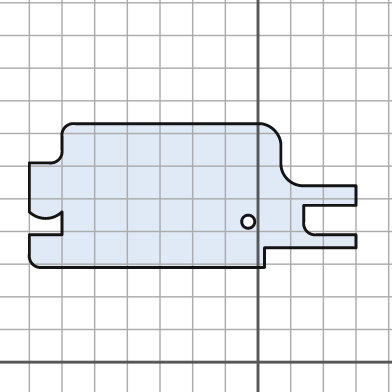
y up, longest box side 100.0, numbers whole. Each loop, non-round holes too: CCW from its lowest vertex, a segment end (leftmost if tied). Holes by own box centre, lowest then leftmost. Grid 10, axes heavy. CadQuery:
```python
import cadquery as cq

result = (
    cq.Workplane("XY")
    .moveTo(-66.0, 29.0)
    .lineTo(2.0, 29.0)
    .lineTo(2.0, 35.0)
    .lineTo(30.0, 35.0)
    .lineTo(30.0, 39.0)
    .lineTo(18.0, 39.0)
    .threePointArc((15.0, 40.0), (14.0, 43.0))
    .lineTo(14.0, 48.0)
    .lineTo(30.0, 48.0)
    .lineTo(30.0, 54.0)
    .lineTo(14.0, 54.0)
    .threePointArc((9.0, 56.0), (7.0, 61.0))
    .lineTo(7.0, 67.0)
    .threePointArc((5.0, 71.0), (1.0, 73.0))
    .lineTo(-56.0, 73.0)
    .threePointArc((-59.0, 72.0), (-60.0, 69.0))
    .lineTo(-60.0, 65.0)
    .threePointArc((-61.0, 62.0), (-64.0, 61.0))
    .lineTo(-70.0, 61.0)
    .lineTo(-70.0, 46.0)
    .threePointArc((-65.0, 44.0), (-60.0, 46.0))
    .lineTo(-60.0, 39.0)
    .lineTo(-70.0, 39.0)
    .lineTo(-70.0, 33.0)
    .threePointArc((-69.0, 30.0), (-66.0, 29.0))
    .close()
    .moveTo(-3.0, 43.0)
    .circle(2.0)
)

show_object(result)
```